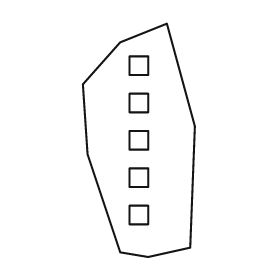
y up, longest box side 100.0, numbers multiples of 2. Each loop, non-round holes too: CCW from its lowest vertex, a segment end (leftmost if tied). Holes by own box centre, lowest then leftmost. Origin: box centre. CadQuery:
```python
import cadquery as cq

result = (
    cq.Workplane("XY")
    .moveTo(4.0, -50.0)
    .lineTo(22.0, -46.0)
    .lineTo(24.0, 6.0)
    .lineTo(12.0, 50.0)
    .lineTo(-8.0, 42.0)
    .lineTo(-24.0, 24.0)
    .lineTo(-22.0, -6.0)
    .lineTo(-8.0, -48.0)
    .close()
    .moveTo(-4.0, -36.0)
    .lineTo(4.0, -36.0)
    .lineTo(4.0, -28.0)
    .lineTo(-4.0, -28.0)
    .close()
    .moveTo(-4.0, -20.0)
    .lineTo(4.0, -20.0)
    .lineTo(4.0, -12.0)
    .lineTo(-4.0, -12.0)
    .close()
    .moveTo(-4.0, -4.0)
    .lineTo(4.0, -4.0)
    .lineTo(4.0, 4.0)
    .lineTo(-4.0, 4.0)
    .close()
    .moveTo(-4.0, 12.0)
    .lineTo(4.0, 12.0)
    .lineTo(4.0, 20.0)
    .lineTo(-4.0, 20.0)
    .close()
    .moveTo(-4.0, 28.0)
    .lineTo(4.0, 28.0)
    .lineTo(4.0, 36.0)
    .lineTo(-4.0, 36.0)
    .close()
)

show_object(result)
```